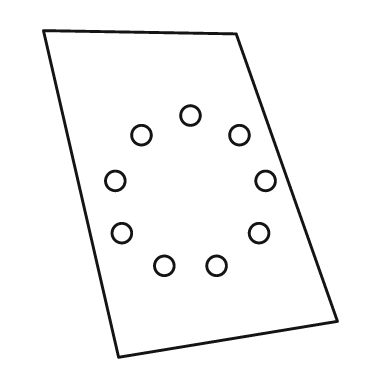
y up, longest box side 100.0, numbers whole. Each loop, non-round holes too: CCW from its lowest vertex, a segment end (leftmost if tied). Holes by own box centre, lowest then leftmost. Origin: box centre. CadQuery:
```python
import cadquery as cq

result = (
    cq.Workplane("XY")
    .moveTo(-22.0, -50.0)
    .lineTo(45.0, -39.0)
    .lineTo(14.0, 49.0)
    .lineTo(-45.0, 50.0)
    .close()
    .moveTo(-8.0, -22.0)
    .circle(3.0)
    .moveTo(8.0, -22.0)
    .circle(3.0)
    .moveTo(-21.0, -12.0)
    .circle(3.0)
    .moveTo(21.0, -12.0)
    .circle(3.0)
    .moveTo(-23.0, 4.0)
    .circle(3.0)
    .moveTo(23.0, 4.0)
    .circle(3.0)
    .moveTo(-15.0, 18.0)
    .circle(3.0)
    .moveTo(15.0, 18.0)
    .circle(3.0)
    .moveTo(0.0, 24.0)
    .circle(3.0)
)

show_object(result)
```